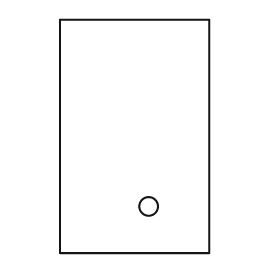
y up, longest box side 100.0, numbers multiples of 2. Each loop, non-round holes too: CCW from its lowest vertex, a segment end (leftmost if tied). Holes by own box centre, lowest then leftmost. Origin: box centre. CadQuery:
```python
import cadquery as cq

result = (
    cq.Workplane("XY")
    .moveTo(-32.0, -50.0)
    .lineTo(32.0, -50.0)
    .lineTo(32.0, 50.0)
    .lineTo(-32.0, 50.0)
    .close()
    .moveTo(6.0, -30.0)
    .circle(4.0)
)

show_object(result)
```